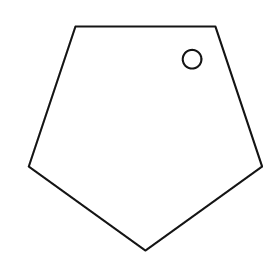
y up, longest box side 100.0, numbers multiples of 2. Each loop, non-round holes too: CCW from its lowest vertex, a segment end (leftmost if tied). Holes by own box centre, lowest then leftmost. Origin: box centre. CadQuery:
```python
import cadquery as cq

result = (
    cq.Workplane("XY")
    .moveTo(0.0, -48.0)
    .lineTo(50.0, -12.0)
    .lineTo(30.0, 48.0)
    .lineTo(-30.0, 48.0)
    .lineTo(-50.0, -12.0)
    .close()
    .moveTo(20.0, 34.0)
    .circle(4.0)
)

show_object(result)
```